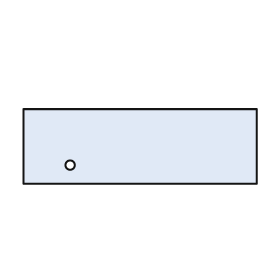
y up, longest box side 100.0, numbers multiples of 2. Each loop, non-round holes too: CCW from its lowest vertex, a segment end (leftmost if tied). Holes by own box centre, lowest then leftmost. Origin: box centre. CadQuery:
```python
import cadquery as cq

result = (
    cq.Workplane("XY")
    .moveTo(-50.0, -16.0)
    .lineTo(50.0, -16.0)
    .lineTo(50.0, 16.0)
    .lineTo(-50.0, 16.0)
    .close()
    .moveTo(-30.0, -8.0)
    .circle(2.0)
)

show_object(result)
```